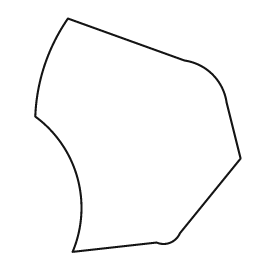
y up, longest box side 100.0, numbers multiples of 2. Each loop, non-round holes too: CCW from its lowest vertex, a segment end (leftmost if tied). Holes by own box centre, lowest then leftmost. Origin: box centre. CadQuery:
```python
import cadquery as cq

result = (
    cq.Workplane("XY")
    .moveTo(-28.0, -50.0)
    .lineTo(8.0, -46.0)
    .threePointArc((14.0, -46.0), (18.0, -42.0))
    .lineTo(44.0, -10.0)
    .lineTo(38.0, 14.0)
    .threePointArc((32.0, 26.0), (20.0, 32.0))
    .lineTo(-30.0, 50.0)
    .threePointArc((-40.0, 30.0), (-44.0, 8.0))
    .threePointArc((-26.0, -18.0), (-28.0, -50.0))
    .close()
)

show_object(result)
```